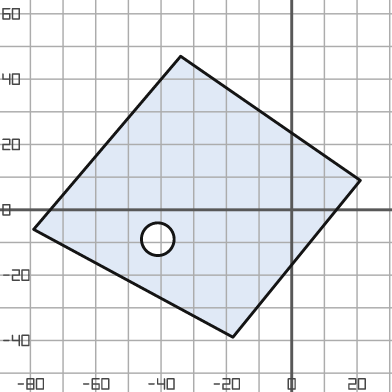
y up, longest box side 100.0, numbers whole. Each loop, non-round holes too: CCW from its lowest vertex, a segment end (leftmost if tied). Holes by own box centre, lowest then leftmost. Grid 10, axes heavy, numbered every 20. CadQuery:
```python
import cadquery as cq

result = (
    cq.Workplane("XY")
    .moveTo(-18.0, -39.0)
    .lineTo(21.0, 9.0)
    .lineTo(-34.0, 47.0)
    .lineTo(-79.0, -6.0)
    .close()
    .moveTo(-41.0, -9.0)
    .circle(5.0)
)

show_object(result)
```